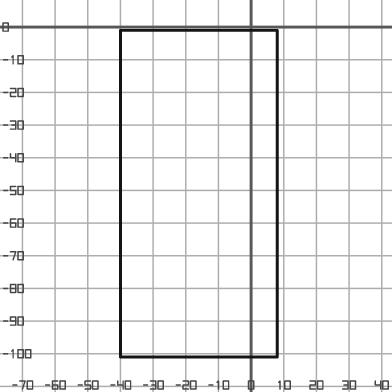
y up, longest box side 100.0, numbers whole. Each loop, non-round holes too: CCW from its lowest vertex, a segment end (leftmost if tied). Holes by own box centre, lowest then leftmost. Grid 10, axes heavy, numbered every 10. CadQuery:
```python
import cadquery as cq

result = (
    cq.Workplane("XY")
    .moveTo(-40.0, -101.0)
    .lineTo(8.0, -101.0)
    .lineTo(8.0, -1.0)
    .lineTo(-40.0, -1.0)
    .close()
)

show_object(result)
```